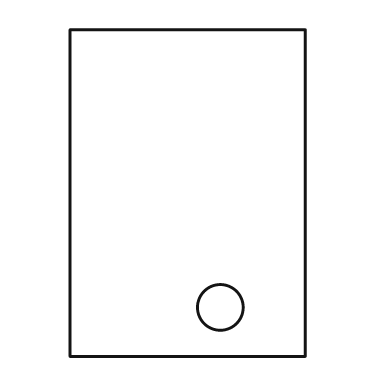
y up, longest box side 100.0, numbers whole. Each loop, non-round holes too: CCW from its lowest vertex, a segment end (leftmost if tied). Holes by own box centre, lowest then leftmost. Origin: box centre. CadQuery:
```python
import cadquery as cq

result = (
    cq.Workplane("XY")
    .moveTo(-36.0, -50.0)
    .lineTo(36.0, -50.0)
    .lineTo(36.0, 50.0)
    .lineTo(-36.0, 50.0)
    .close()
    .moveTo(10.0, -35.0)
    .circle(7.0)
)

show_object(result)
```